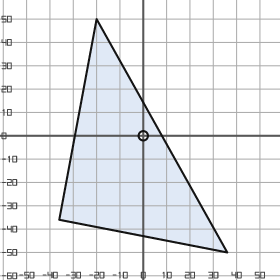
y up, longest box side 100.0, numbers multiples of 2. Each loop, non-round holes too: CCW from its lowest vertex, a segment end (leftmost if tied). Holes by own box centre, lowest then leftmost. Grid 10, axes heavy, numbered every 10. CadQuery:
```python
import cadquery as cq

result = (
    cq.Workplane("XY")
    .moveTo(36.0, -50.0)
    .lineTo(-20.0, 50.0)
    .lineTo(-36.0, -36.0)
    .close()
    .moveTo(0.0, 0.0)
    .circle(2.0)
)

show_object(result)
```